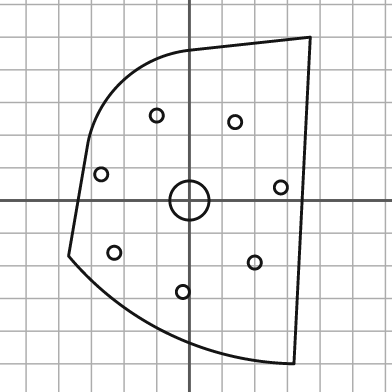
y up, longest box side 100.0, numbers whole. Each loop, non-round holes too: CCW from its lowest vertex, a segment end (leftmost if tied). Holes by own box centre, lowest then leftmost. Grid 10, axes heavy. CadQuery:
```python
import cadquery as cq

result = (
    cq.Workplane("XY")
    .moveTo(32.0, -50.0)
    .lineTo(37.0, 50.0)
    .lineTo(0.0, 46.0)
    .threePointArc((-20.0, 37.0), (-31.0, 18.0))
    .lineTo(-37.0, -17.0)
    .threePointArc((-6.0, -41.0), (32.0, -50.0))
    .close()
    .moveTo(-2.0, -28.0)
    .circle(2.0)
    .moveTo(20.0, -19.0)
    .circle(2.0)
    .moveTo(-23.0, -16.0)
    .circle(2.0)
    .moveTo(0.0, 0.0)
    .circle(6.0)
    .moveTo(28.0, 4.0)
    .circle(2.0)
    .moveTo(-27.0, 8.0)
    .circle(2.0)
    .moveTo(14.0, 24.0)
    .circle(2.0)
    .moveTo(-10.0, 26.0)
    .circle(2.0)
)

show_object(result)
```